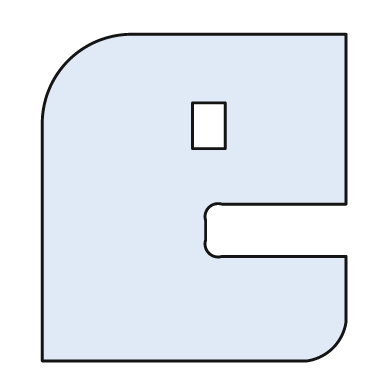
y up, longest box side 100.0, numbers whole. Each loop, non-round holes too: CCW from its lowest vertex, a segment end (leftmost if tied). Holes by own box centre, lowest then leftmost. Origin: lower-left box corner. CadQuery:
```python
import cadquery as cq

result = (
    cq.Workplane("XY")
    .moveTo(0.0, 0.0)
    .lineTo(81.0, 0.0)
    .threePointArc((89.0, 4.0), (93.0, 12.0))
    .lineTo(93.0, 32.0)
    .lineTo(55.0, 32.0)
    .threePointArc((51.0, 33.0), (50.0, 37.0))
    .lineTo(50.0, 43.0)
    .threePointArc((51.0, 47.0), (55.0, 48.0))
    .lineTo(93.0, 48.0)
    .lineTo(93.0, 100.0)
    .lineTo(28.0, 100.0)
    .threePointArc((8.0, 92.0), (0.0, 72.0))
    .close()
    .moveTo(46.0, 65.0)
    .lineTo(56.0, 65.0)
    .lineTo(56.0, 79.0)
    .lineTo(46.0, 79.0)
    .close()
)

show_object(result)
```